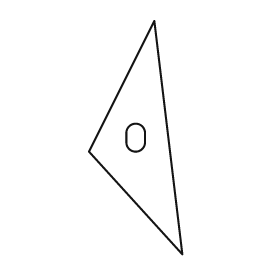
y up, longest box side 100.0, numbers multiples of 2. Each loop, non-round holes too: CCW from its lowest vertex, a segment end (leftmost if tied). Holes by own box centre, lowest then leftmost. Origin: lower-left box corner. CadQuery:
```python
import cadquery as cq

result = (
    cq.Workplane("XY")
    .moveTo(40.0, 0.0)
    .lineTo(28.0, 100.0)
    .lineTo(0.0, 44.0)
    .close()
    .moveTo(16.0, 48.0)
    .threePointArc((20.0, 44.0), (24.0, 48.0))
    .lineTo(24.0, 52.0)
    .threePointArc((20.0, 56.0), (16.0, 52.0))
    .close()
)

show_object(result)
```